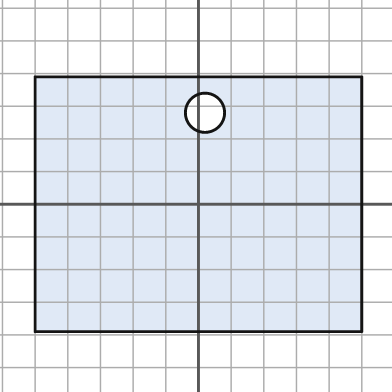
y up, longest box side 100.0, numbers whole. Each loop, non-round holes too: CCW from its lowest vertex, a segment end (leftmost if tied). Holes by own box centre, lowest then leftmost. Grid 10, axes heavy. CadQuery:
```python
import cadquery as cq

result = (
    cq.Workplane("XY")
    .moveTo(-50.0, -39.0)
    .lineTo(50.0, -39.0)
    .lineTo(50.0, 39.0)
    .lineTo(-50.0, 39.0)
    .close()
    .moveTo(2.0, 28.0)
    .circle(6.0)
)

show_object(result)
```